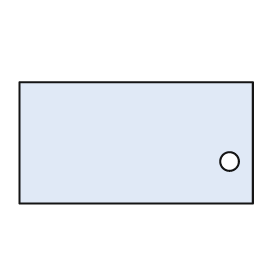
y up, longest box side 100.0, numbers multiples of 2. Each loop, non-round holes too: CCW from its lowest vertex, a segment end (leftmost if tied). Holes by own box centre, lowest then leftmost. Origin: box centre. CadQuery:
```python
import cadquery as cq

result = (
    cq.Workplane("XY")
    .moveTo(-50.0, -26.0)
    .lineTo(50.0, -26.0)
    .lineTo(50.0, 26.0)
    .lineTo(-50.0, 26.0)
    .close()
    .moveTo(40.0, -8.0)
    .circle(4.0)
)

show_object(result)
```